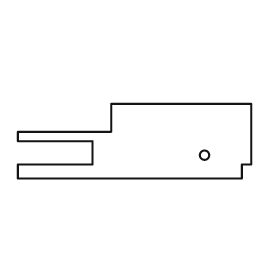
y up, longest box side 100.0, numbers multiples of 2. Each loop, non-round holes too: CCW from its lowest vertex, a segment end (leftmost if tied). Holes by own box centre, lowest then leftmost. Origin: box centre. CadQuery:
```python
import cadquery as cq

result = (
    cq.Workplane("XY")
    .moveTo(-50.0, -16.0)
    .lineTo(46.0, -16.0)
    .lineTo(46.0, -10.0)
    .lineTo(50.0, -10.0)
    .lineTo(50.0, 16.0)
    .lineTo(-10.0, 16.0)
    .lineTo(-10.0, 4.0)
    .lineTo(-50.0, 4.0)
    .lineTo(-50.0, 0.0)
    .lineTo(-18.0, 0.0)
    .lineTo(-18.0, -10.0)
    .lineTo(-50.0, -10.0)
    .close()
    .moveTo(30.0, -6.0)
    .circle(2.0)
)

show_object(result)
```